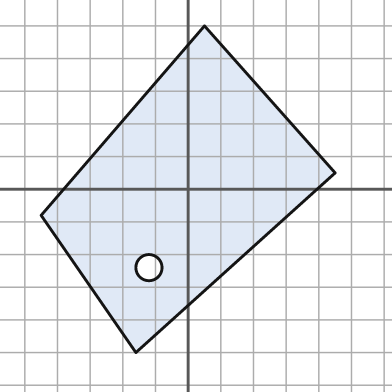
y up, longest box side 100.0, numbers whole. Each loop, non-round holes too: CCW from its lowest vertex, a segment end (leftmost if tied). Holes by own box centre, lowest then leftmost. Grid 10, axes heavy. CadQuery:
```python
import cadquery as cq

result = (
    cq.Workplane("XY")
    .moveTo(-16.0, -50.0)
    .lineTo(45.0, 5.0)
    .lineTo(5.0, 50.0)
    .lineTo(-45.0, -8.0)
    .close()
    .moveTo(-12.0, -24.0)
    .circle(4.0)
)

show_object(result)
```